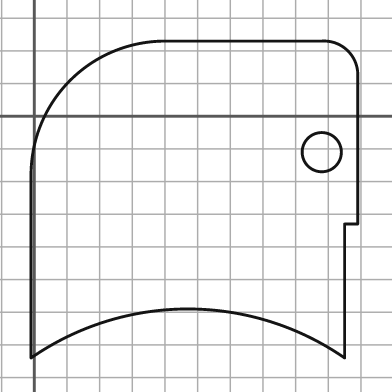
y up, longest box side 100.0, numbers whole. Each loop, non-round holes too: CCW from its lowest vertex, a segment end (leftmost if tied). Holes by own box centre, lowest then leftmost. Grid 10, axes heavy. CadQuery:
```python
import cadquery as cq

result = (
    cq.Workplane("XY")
    .moveTo(-1.0, -74.0)
    .threePointArc((47.0, -59.0), (95.0, -74.0))
    .lineTo(95.0, -33.0)
    .lineTo(99.0, -33.0)
    .lineTo(99.0, 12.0)
    .threePointArc((96.0, 20.0), (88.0, 23.0))
    .lineTo(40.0, 23.0)
    .threePointArc((11.0, 11.0), (-1.0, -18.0))
    .close()
    .moveTo(88.0, -11.0)
    .circle(6.0)
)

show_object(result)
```